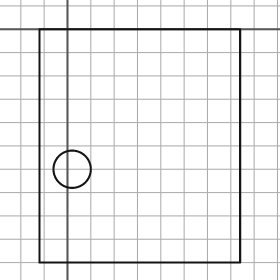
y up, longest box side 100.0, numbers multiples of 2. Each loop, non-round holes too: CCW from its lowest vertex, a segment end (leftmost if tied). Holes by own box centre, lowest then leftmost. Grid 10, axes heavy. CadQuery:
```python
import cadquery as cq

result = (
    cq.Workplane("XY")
    .moveTo(-12.0, -100.0)
    .lineTo(74.0, -100.0)
    .lineTo(74.0, 0.0)
    .lineTo(-12.0, 0.0)
    .close()
    .moveTo(2.0, -60.0)
    .circle(8.0)
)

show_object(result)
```